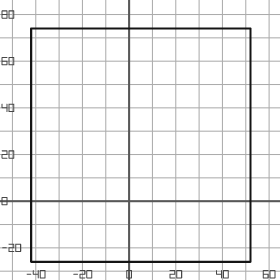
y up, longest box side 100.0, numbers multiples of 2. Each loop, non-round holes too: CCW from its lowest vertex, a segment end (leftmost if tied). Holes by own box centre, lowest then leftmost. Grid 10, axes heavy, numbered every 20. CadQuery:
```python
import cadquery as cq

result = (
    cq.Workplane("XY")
    .moveTo(-42.0, -26.0)
    .lineTo(52.0, -26.0)
    .lineTo(52.0, 74.0)
    .lineTo(-42.0, 74.0)
    .close()
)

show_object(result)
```